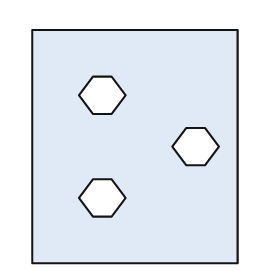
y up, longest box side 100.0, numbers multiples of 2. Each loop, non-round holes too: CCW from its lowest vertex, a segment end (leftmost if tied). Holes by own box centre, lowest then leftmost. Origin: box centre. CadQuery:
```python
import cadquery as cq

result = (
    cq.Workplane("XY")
    .moveTo(-44.0, -50.0)
    .lineTo(44.0, -50.0)
    .lineTo(44.0, 50.0)
    .lineTo(-44.0, 50.0)
    .close()
    .moveTo(-18.0, -30.0)
    .lineTo(-10.0, -30.0)
    .lineTo(-4.0, -22.0)
    .lineTo(-10.0, -14.0)
    .lineTo(-18.0, -14.0)
    .lineTo(-24.0, -22.0)
    .close()
    .moveTo(22.0, -8.0)
    .lineTo(30.0, -8.0)
    .lineTo(36.0, 0.0)
    .lineTo(30.0, 8.0)
    .lineTo(22.0, 8.0)
    .lineTo(16.0, 0.0)
    .close()
    .moveTo(-18.0, 14.0)
    .lineTo(-10.0, 14.0)
    .lineTo(-4.0, 22.0)
    .lineTo(-10.0, 30.0)
    .lineTo(-18.0, 30.0)
    .lineTo(-24.0, 22.0)
    .close()
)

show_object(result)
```